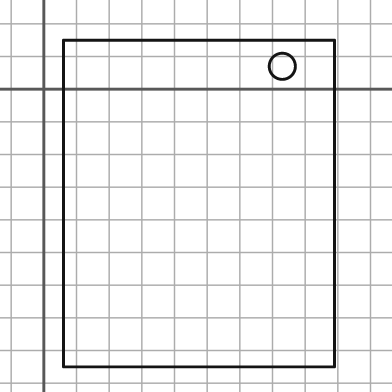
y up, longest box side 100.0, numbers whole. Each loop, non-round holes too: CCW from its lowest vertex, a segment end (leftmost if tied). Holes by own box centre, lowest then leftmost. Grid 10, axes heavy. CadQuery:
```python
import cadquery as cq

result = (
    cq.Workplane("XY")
    .moveTo(6.0, -85.0)
    .lineTo(89.0, -85.0)
    .lineTo(89.0, 15.0)
    .lineTo(6.0, 15.0)
    .close()
    .moveTo(73.0, 7.0)
    .circle(4.0)
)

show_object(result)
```